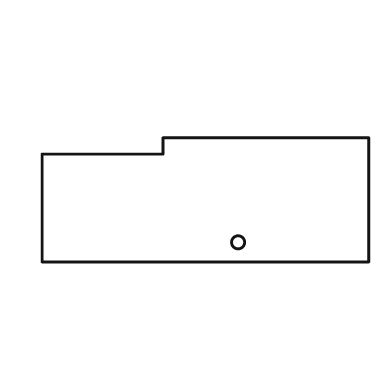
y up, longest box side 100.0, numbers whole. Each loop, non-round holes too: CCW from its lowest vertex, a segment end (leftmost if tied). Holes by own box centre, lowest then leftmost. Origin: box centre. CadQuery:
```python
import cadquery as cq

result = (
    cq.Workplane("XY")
    .moveTo(-50.0, -19.0)
    .lineTo(50.0, -19.0)
    .lineTo(50.0, 19.0)
    .lineTo(-13.0, 19.0)
    .lineTo(-13.0, 14.0)
    .lineTo(-50.0, 14.0)
    .close()
    .moveTo(10.0, -13.0)
    .circle(2.0)
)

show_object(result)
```